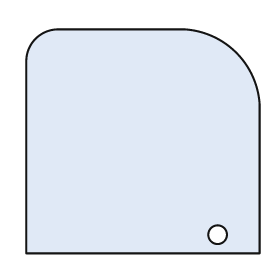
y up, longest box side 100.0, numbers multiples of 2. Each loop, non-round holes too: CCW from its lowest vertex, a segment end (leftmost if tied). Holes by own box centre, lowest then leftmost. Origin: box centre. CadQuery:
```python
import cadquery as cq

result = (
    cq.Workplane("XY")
    .moveTo(-50.0, -48.0)
    .lineTo(50.0, -48.0)
    .lineTo(50.0, 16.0)
    .threePointArc((40.0, 38.0), (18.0, 48.0))
    .lineTo(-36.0, 48.0)
    .threePointArc((-46.0, 44.0), (-50.0, 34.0))
    .close()
    .moveTo(32.0, -40.0)
    .circle(4.0)
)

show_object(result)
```